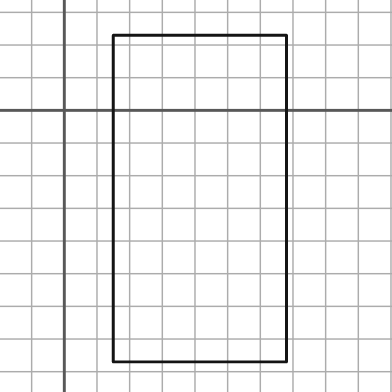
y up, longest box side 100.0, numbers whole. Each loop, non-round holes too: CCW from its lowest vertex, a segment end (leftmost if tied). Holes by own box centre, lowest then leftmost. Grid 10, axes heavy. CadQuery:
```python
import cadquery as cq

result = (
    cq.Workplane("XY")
    .moveTo(15.0, -77.0)
    .lineTo(68.0, -77.0)
    .lineTo(68.0, 23.0)
    .lineTo(15.0, 23.0)
    .close()
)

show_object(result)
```